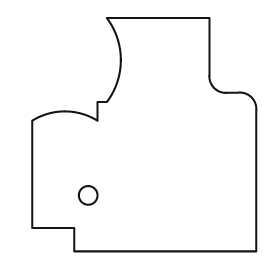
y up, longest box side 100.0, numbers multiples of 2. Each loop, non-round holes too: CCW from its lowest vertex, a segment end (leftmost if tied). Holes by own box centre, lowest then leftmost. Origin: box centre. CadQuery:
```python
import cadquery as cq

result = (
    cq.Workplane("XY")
    .moveTo(-30.0, -50.0)
    .lineTo(48.0, -50.0)
    .lineTo(48.0, 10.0)
    .threePointArc((46.0, 16.0), (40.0, 18.0))
    .lineTo(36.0, 18.0)
    .threePointArc((30.0, 20.0), (28.0, 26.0))
    .lineTo(28.0, 50.0)
    .lineTo(-16.0, 50.0)
    .threePointArc((-10.0, 32.0), (-16.0, 14.0))
    .lineTo(-20.0, 14.0)
    .lineTo(-20.0, 6.0)
    .threePointArc((-34.0, 10.0), (-48.0, 6.0))
    .lineTo(-48.0, -40.0)
    .lineTo(-30.0, -40.0)
    .close()
    .moveTo(-24.0, -26.0)
    .circle(4.0)
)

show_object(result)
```